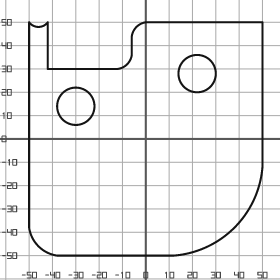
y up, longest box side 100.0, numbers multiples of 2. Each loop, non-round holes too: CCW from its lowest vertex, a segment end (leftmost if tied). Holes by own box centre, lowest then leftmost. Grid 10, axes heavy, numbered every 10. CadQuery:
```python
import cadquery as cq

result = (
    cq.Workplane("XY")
    .moveTo(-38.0, -50.0)
    .lineTo(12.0, -50.0)
    .threePointArc((38.0, -38.0), (50.0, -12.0))
    .lineTo(50.0, 50.0)
    .lineTo(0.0, 50.0)
    .threePointArc((-4.0, 48.0), (-6.0, 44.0))
    .lineTo(-6.0, 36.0)
    .threePointArc((-8.0, 32.0), (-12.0, 30.0))
    .lineTo(-42.0, 30.0)
    .lineTo(-42.0, 50.0)
    .threePointArc((-46.0, 48.0), (-50.0, 50.0))
    .lineTo(-50.0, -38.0)
    .threePointArc((-46.0, -46.0), (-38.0, -50.0))
    .close()
    .moveTo(-30.0, 14.0)
    .circle(8.0)
    .moveTo(22.0, 28.0)
    .circle(8.0)
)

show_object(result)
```